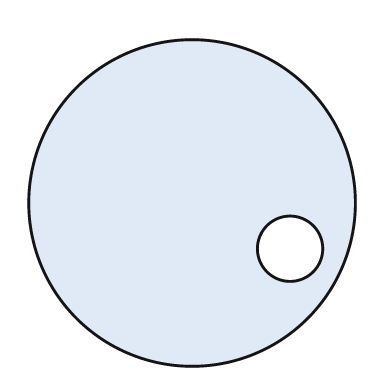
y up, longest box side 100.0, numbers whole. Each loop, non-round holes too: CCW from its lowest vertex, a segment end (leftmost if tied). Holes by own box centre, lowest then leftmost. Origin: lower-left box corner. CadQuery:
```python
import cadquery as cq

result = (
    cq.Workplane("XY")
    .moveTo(50.0, 50.0)
    .circle(50.0)
    .moveTo(80.0, 36.0)
    .circle(10.0)
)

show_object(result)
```